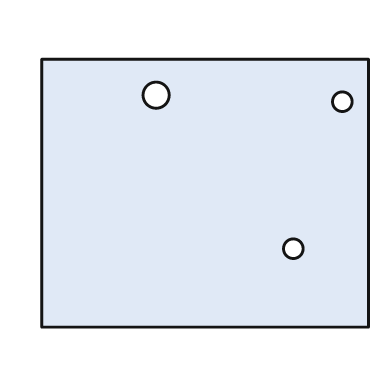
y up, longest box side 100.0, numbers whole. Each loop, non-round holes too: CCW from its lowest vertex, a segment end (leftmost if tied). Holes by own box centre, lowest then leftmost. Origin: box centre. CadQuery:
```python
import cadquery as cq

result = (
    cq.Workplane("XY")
    .moveTo(-50.0, -41.0)
    .lineTo(50.0, -41.0)
    .lineTo(50.0, 41.0)
    .lineTo(-50.0, 41.0)
    .close()
    .moveTo(27.0, -17.0)
    .circle(3.0)
    .moveTo(42.0, 28.0)
    .circle(3.0)
    .moveTo(-15.0, 30.0)
    .circle(4.0)
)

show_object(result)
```